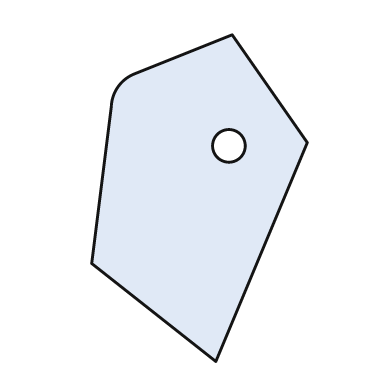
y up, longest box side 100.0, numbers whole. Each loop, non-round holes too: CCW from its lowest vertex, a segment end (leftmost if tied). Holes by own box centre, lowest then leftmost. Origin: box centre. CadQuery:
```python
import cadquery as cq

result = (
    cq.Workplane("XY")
    .moveTo(5.0, -50.0)
    .lineTo(33.0, 17.0)
    .lineTo(10.0, 50.0)
    .lineTo(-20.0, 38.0)
    .threePointArc((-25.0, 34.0), (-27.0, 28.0))
    .lineTo(-33.0, -20.0)
    .close()
    .moveTo(9.0, 16.0)
    .circle(5.0)
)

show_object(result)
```